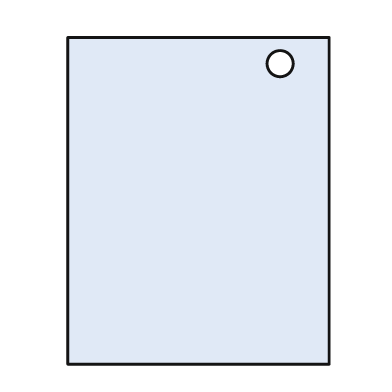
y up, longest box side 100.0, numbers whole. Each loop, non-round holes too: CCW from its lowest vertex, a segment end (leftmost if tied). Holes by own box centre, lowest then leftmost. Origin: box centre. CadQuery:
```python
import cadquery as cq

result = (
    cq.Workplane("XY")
    .moveTo(-40.0, -50.0)
    .lineTo(40.0, -50.0)
    .lineTo(40.0, 50.0)
    .lineTo(-40.0, 50.0)
    .close()
    .moveTo(25.0, 42.0)
    .circle(4.0)
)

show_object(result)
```